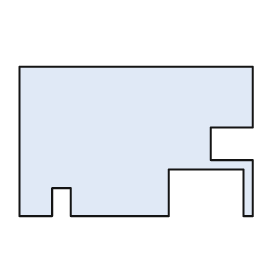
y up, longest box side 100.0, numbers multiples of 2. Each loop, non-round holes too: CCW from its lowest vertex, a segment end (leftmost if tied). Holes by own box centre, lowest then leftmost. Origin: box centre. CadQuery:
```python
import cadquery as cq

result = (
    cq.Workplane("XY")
    .moveTo(-50.0, -32.0)
    .lineTo(-36.0, -32.0)
    .lineTo(-36.0, -20.0)
    .lineTo(-28.0, -20.0)
    .lineTo(-28.0, -32.0)
    .lineTo(14.0, -32.0)
    .lineTo(14.0, -12.0)
    .lineTo(46.0, -12.0)
    .lineTo(46.0, -32.0)
    .lineTo(50.0, -32.0)
    .lineTo(50.0, -8.0)
    .lineTo(32.0, -8.0)
    .lineTo(32.0, 6.0)
    .lineTo(50.0, 6.0)
    .lineTo(50.0, 32.0)
    .lineTo(-50.0, 32.0)
    .close()
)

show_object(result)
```